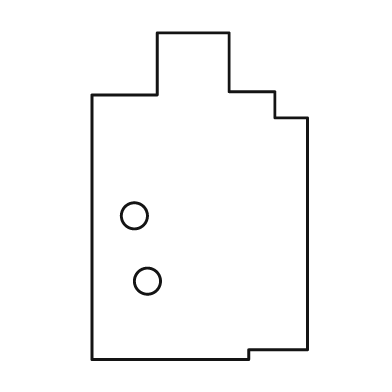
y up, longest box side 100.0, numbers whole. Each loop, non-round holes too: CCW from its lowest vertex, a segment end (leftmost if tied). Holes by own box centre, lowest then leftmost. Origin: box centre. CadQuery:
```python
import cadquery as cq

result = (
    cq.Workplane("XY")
    .moveTo(-33.0, -50.0)
    .lineTo(15.0, -50.0)
    .lineTo(15.0, -47.0)
    .lineTo(33.0, -47.0)
    .lineTo(33.0, 24.0)
    .lineTo(23.0, 24.0)
    .lineTo(23.0, 32.0)
    .lineTo(9.0, 32.0)
    .lineTo(9.0, 50.0)
    .lineTo(-13.0, 50.0)
    .lineTo(-13.0, 31.0)
    .lineTo(-33.0, 31.0)
    .close()
    .moveTo(-16.0, -26.0)
    .circle(4.0)
    .moveTo(-20.0, -6.0)
    .circle(4.0)
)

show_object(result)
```